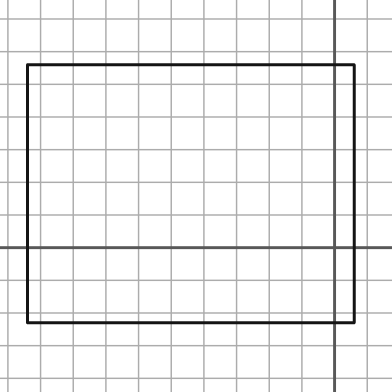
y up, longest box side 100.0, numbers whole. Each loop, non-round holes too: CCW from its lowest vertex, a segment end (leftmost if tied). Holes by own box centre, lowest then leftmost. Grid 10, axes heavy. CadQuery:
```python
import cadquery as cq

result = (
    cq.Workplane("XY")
    .moveTo(-94.0, -23.0)
    .lineTo(6.0, -23.0)
    .lineTo(6.0, 56.0)
    .lineTo(-94.0, 56.0)
    .close()
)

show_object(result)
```